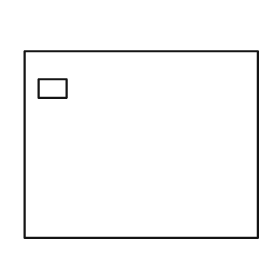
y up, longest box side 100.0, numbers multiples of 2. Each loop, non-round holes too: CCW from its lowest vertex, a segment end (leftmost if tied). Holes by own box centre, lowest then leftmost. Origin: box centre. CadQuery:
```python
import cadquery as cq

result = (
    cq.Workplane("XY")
    .moveTo(-50.0, -40.0)
    .lineTo(50.0, -40.0)
    .lineTo(50.0, 40.0)
    .lineTo(-50.0, 40.0)
    .close()
    .moveTo(-44.0, 20.0)
    .lineTo(-32.0, 20.0)
    .lineTo(-32.0, 28.0)
    .lineTo(-44.0, 28.0)
    .close()
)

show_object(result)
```